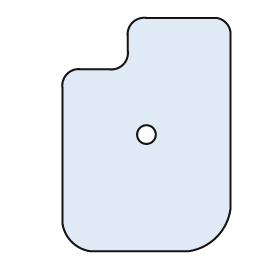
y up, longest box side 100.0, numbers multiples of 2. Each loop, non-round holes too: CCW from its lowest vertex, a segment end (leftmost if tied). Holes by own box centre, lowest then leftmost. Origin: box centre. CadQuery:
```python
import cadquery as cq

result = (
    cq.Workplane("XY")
    .moveTo(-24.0, -50.0)
    .lineTo(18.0, -50.0)
    .threePointArc((30.0, -44.0), (36.0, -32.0))
    .lineTo(36.0, 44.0)
    .threePointArc((34.0, 48.0), (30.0, 50.0))
    .lineTo(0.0, 50.0)
    .threePointArc((-6.0, 48.0), (-8.0, 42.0))
    .lineTo(-8.0, 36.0)
    .threePointArc((-10.0, 30.0), (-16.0, 28.0))
    .lineTo(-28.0, 28.0)
    .threePointArc((-34.0, 26.0), (-36.0, 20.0))
    .lineTo(-36.0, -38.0)
    .threePointArc((-32.0, -46.0), (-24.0, -50.0))
    .close()
    .moveTo(0.0, 0.0)
    .circle(4.0)
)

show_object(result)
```